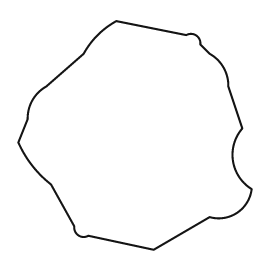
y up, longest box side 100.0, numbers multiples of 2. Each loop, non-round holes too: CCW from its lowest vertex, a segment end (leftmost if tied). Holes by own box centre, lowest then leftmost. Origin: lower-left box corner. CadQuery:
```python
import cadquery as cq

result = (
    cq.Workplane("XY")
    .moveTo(58.0, 0.0)
    .lineTo(82.0, 14.0)
    .threePointArc((94.0, 16.0), (100.0, 26.0))
    .threePointArc((92.0, 38.0), (96.0, 52.0))
    .lineTo(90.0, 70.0)
    .threePointArc((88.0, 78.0), (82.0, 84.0))
    .lineTo(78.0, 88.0)
    .threePointArc((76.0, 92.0), (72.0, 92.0))
    .lineTo(42.0, 98.0)
    .threePointArc((34.0, 92.0), (28.0, 84.0))
    .lineTo(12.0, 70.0)
    .threePointArc((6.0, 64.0), (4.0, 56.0))
    .lineTo(0.0, 46.0)
    .threePointArc((6.0, 36.0), (14.0, 28.0))
    .lineTo(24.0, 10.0)
    .threePointArc((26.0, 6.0), (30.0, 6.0))
    .close()
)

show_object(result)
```